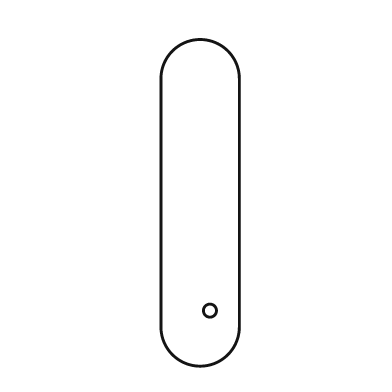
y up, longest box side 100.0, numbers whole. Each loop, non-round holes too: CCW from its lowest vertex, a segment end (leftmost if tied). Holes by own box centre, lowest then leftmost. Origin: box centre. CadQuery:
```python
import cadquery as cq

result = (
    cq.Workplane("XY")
    .moveTo(-12.0, -38.0)
    .threePointArc((0.0, -50.0), (12.0, -38.0))
    .lineTo(12.0, 38.0)
    .threePointArc((0.0, 50.0), (-12.0, 38.0))
    .close()
    .moveTo(3.0, -33.0)
    .circle(2.0)
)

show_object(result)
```